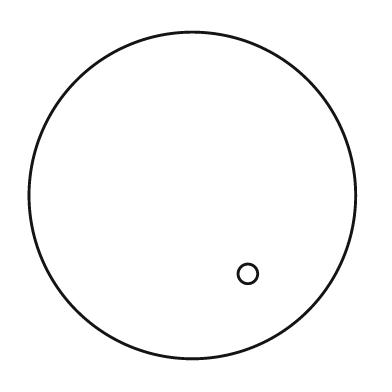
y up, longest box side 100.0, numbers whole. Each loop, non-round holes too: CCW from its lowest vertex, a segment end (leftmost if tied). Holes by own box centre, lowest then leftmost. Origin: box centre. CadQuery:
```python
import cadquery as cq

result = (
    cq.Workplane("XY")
    .moveTo(0.0, 0.0)
    .circle(50.0)
    .moveTo(17.0, -24.0)
    .circle(3.0)
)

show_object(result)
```